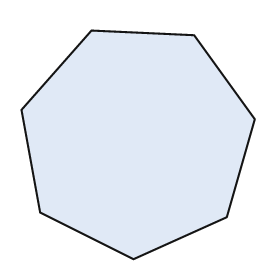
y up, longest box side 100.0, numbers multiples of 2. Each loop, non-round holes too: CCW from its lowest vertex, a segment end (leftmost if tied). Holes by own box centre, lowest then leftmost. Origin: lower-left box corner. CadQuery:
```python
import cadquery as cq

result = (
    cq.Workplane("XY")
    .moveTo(48.0, 0.0)
    .lineTo(88.0, 18.0)
    .lineTo(100.0, 60.0)
    .lineTo(74.0, 96.0)
    .lineTo(30.0, 98.0)
    .lineTo(0.0, 64.0)
    .lineTo(8.0, 20.0)
    .close()
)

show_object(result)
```